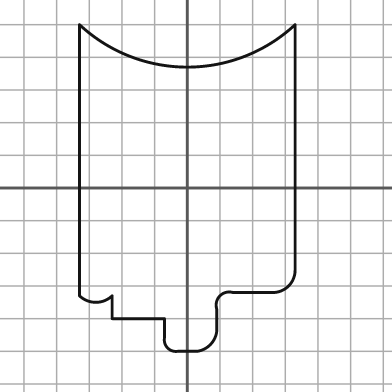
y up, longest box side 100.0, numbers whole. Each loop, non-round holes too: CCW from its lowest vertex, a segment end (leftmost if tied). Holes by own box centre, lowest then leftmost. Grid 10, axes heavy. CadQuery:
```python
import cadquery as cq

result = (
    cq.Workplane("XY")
    .moveTo(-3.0, -50.0)
    .lineTo(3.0, -50.0)
    .threePointArc((7.0, -48.0), (9.0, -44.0))
    .lineTo(9.0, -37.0)
    .threePointArc((10.0, -33.0), (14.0, -32.0))
    .lineTo(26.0, -32.0)
    .threePointArc((31.0, -30.0), (33.0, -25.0))
    .lineTo(33.0, 50.0)
    .threePointArc((0.0, 37.0), (-33.0, 50.0))
    .lineTo(-33.0, -33.0)
    .threePointArc((-28.0, -35.0), (-23.0, -33.0))
    .lineTo(-23.0, -40.0)
    .lineTo(-7.0, -40.0)
    .lineTo(-7.0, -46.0)
    .threePointArc((-6.0, -49.0), (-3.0, -50.0))
    .close()
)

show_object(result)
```